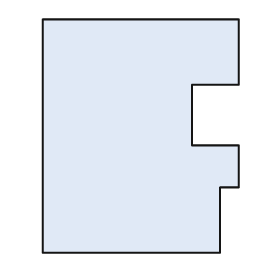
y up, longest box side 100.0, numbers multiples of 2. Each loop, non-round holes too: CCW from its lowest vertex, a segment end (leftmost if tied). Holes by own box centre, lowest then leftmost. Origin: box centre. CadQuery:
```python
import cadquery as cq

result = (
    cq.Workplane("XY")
    .moveTo(-42.0, -50.0)
    .lineTo(34.0, -50.0)
    .lineTo(34.0, -22.0)
    .lineTo(42.0, -22.0)
    .lineTo(42.0, -4.0)
    .lineTo(22.0, -4.0)
    .lineTo(22.0, 22.0)
    .lineTo(42.0, 22.0)
    .lineTo(42.0, 50.0)
    .lineTo(-42.0, 50.0)
    .close()
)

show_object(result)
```